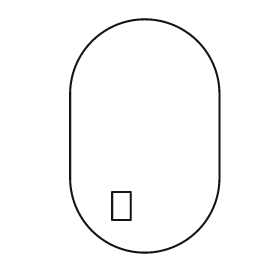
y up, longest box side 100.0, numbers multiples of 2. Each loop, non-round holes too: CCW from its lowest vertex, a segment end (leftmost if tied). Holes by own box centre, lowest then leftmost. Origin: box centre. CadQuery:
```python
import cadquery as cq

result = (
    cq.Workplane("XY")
    .moveTo(-32.0, -18.0)
    .threePointArc((0.0, -50.0), (32.0, -18.0))
    .lineTo(32.0, 18.0)
    .threePointArc((0.0, 50.0), (-32.0, 18.0))
    .close()
    .moveTo(-14.0, -36.0)
    .lineTo(-6.0, -36.0)
    .lineTo(-6.0, -24.0)
    .lineTo(-14.0, -24.0)
    .close()
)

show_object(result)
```